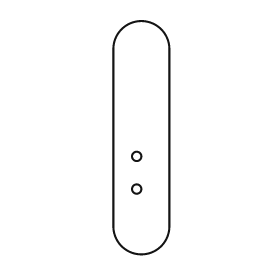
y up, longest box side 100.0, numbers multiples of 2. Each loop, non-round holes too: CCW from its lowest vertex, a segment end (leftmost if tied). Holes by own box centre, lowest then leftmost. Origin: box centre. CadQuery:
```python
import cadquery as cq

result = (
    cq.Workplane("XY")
    .moveTo(-12.0, -38.0)
    .threePointArc((0.0, -50.0), (12.0, -38.0))
    .lineTo(12.0, 38.0)
    .threePointArc((0.0, 50.0), (-12.0, 38.0))
    .close()
    .moveTo(-2.0, -22.0)
    .circle(2.0)
    .moveTo(-2.0, -8.0)
    .circle(2.0)
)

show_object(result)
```